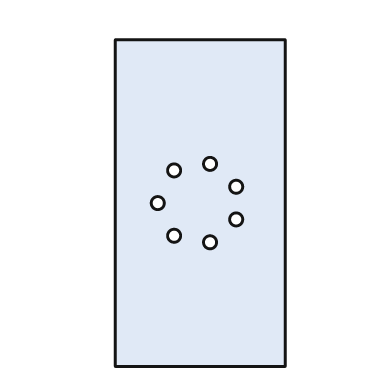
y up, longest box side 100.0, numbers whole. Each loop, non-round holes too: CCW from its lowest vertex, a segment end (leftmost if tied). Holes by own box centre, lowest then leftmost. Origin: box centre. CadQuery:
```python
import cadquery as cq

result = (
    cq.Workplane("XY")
    .moveTo(-26.0, -50.0)
    .lineTo(26.0, -50.0)
    .lineTo(26.0, 50.0)
    .lineTo(-26.0, 50.0)
    .close()
    .moveTo(3.0, -12.0)
    .circle(2.0)
    .moveTo(-8.0, -10.0)
    .circle(2.0)
    .moveTo(11.0, -5.0)
    .circle(2.0)
    .moveTo(-13.0, 0.0)
    .circle(2.0)
    .moveTo(11.0, 5.0)
    .circle(2.0)
    .moveTo(-8.0, 10.0)
    .circle(2.0)
    .moveTo(3.0, 12.0)
    .circle(2.0)
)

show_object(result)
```